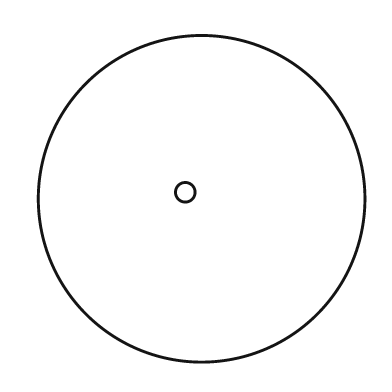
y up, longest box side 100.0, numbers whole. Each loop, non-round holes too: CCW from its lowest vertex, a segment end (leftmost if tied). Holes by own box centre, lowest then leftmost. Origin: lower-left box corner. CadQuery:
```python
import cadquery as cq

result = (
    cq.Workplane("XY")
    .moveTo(50.0, 50.0)
    .circle(50.0)
    .moveTo(45.0, 52.0)
    .circle(3.0)
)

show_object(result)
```